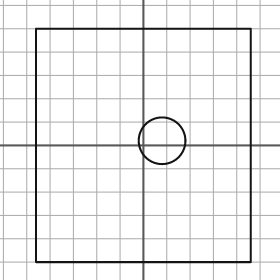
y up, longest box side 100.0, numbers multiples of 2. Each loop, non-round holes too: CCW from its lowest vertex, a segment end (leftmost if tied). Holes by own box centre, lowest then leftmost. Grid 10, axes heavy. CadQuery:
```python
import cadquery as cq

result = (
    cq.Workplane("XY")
    .moveTo(-46.0, -50.0)
    .lineTo(46.0, -50.0)
    .lineTo(46.0, 50.0)
    .lineTo(-46.0, 50.0)
    .close()
    .moveTo(8.0, 2.0)
    .circle(10.0)
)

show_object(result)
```